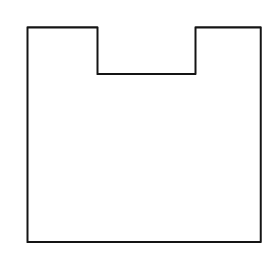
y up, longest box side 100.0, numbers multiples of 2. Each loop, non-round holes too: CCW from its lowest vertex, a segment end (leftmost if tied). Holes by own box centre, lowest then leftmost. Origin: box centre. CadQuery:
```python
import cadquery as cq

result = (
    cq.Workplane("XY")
    .moveTo(-50.0, -46.0)
    .lineTo(50.0, -46.0)
    .lineTo(50.0, 46.0)
    .lineTo(22.0, 46.0)
    .lineTo(22.0, 26.0)
    .lineTo(-20.0, 26.0)
    .lineTo(-20.0, 46.0)
    .lineTo(-50.0, 46.0)
    .close()
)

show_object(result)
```